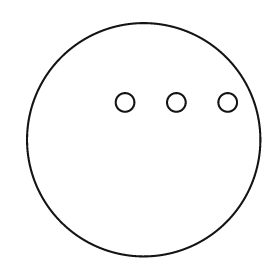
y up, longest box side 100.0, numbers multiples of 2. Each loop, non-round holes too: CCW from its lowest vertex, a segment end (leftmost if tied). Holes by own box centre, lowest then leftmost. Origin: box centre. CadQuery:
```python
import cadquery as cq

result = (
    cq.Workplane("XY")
    .moveTo(0.0, 0.0)
    .circle(50.0)
    .moveTo(-8.0, 16.0)
    .circle(4.0)
    .moveTo(14.0, 16.0)
    .circle(4.0)
    .moveTo(36.0, 16.0)
    .circle(4.0)
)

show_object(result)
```